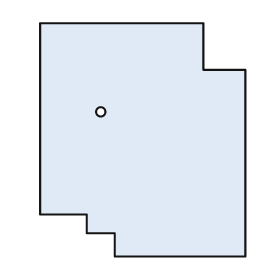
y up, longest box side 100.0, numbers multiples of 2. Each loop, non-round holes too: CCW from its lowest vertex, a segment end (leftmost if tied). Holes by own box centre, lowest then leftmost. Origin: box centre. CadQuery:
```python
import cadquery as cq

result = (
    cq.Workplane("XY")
    .moveTo(-12.0, -50.0)
    .lineTo(44.0, -50.0)
    .lineTo(44.0, 30.0)
    .lineTo(26.0, 30.0)
    .lineTo(26.0, 50.0)
    .lineTo(-44.0, 50.0)
    .lineTo(-44.0, -32.0)
    .lineTo(-24.0, -32.0)
    .lineTo(-24.0, -40.0)
    .lineTo(-12.0, -40.0)
    .close()
    .moveTo(-18.0, 12.0)
    .circle(2.0)
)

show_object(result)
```